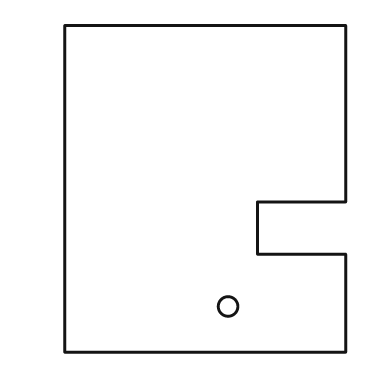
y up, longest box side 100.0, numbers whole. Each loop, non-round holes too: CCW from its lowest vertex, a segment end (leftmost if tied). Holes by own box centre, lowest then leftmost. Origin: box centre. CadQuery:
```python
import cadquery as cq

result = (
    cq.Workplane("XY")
    .moveTo(-43.0, -50.0)
    .lineTo(43.0, -50.0)
    .lineTo(43.0, -20.0)
    .lineTo(16.0, -20.0)
    .lineTo(16.0, -4.0)
    .lineTo(43.0, -4.0)
    .lineTo(43.0, 50.0)
    .lineTo(-43.0, 50.0)
    .close()
    .moveTo(7.0, -36.0)
    .circle(3.0)
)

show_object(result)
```